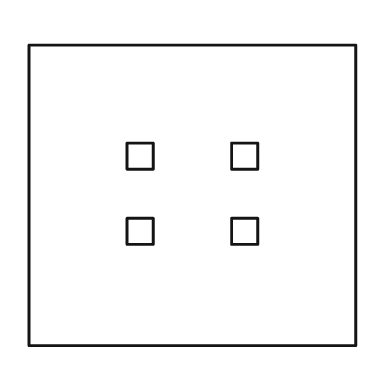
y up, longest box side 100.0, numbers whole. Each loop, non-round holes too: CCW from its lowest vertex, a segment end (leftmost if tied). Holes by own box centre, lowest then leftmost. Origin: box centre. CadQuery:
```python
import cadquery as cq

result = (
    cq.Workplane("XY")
    .moveTo(-50.0, -46.0)
    .lineTo(50.0, -46.0)
    .lineTo(50.0, 46.0)
    .lineTo(-50.0, 46.0)
    .close()
    .moveTo(-20.0, -15.0)
    .lineTo(-12.0, -15.0)
    .lineTo(-12.0, -7.0)
    .lineTo(-20.0, -7.0)
    .close()
    .moveTo(12.0, -15.0)
    .lineTo(20.0, -15.0)
    .lineTo(20.0, -7.0)
    .lineTo(12.0, -7.0)
    .close()
    .moveTo(-20.0, 8.0)
    .lineTo(-12.0, 8.0)
    .lineTo(-12.0, 16.0)
    .lineTo(-20.0, 16.0)
    .close()
    .moveTo(12.0, 8.0)
    .lineTo(20.0, 8.0)
    .lineTo(20.0, 16.0)
    .lineTo(12.0, 16.0)
    .close()
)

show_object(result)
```